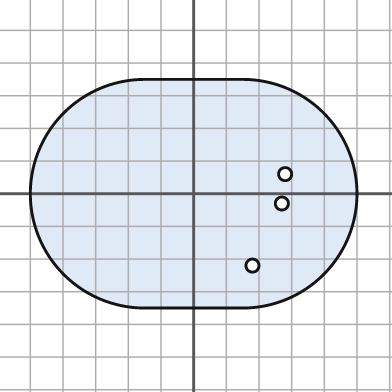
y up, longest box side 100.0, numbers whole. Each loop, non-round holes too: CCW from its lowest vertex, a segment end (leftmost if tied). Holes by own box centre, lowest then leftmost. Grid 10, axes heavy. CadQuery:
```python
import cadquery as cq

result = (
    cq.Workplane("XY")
    .moveTo(-15.0, -35.0)
    .lineTo(15.0, -35.0)
    .threePointArc((50.0, 0.0), (15.0, 35.0))
    .lineTo(-15.0, 35.0)
    .threePointArc((-50.0, 0.0), (-15.0, -35.0))
    .close()
    .moveTo(18.0, -22.0)
    .circle(2.0)
    .moveTo(27.0, -3.0)
    .circle(2.0)
    .moveTo(28.0, 6.0)
    .circle(2.0)
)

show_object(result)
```